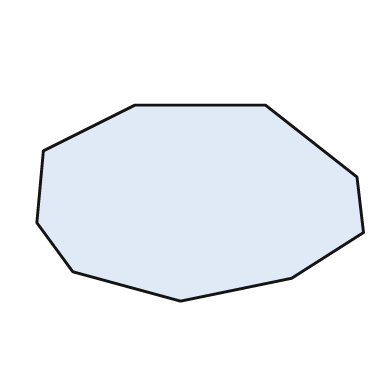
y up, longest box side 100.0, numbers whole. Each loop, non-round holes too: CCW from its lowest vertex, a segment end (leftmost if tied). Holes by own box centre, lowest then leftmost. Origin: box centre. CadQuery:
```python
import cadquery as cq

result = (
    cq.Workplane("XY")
    .moveTo(-6.0, -30.0)
    .lineTo(28.0, -23.0)
    .lineTo(50.0, -9.0)
    .lineTo(48.0, 8.0)
    .lineTo(20.0, 30.0)
    .lineTo(-20.0, 30.0)
    .lineTo(-48.0, 16.0)
    .lineTo(-50.0, -6.0)
    .lineTo(-39.0, -21.0)
    .close()
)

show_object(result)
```